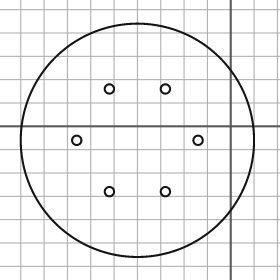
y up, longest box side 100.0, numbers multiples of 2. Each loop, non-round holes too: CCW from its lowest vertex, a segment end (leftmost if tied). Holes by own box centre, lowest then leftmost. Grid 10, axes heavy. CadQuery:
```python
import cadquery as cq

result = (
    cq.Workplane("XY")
    .moveTo(-40.0, -6.0)
    .circle(50.0)
    .moveTo(-52.0, -28.0)
    .circle(2.0)
    .moveTo(-28.0, -28.0)
    .circle(2.0)
    .moveTo(-66.0, -6.0)
    .circle(2.0)
    .moveTo(-14.0, -6.0)
    .circle(2.0)
    .moveTo(-52.0, 16.0)
    .circle(2.0)
    .moveTo(-28.0, 16.0)
    .circle(2.0)
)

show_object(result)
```